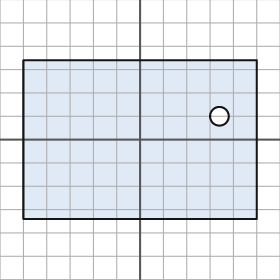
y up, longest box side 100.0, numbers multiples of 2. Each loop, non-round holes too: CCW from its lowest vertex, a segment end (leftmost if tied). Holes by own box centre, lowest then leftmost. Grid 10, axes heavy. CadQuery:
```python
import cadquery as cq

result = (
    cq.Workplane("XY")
    .moveTo(-50.0, -34.0)
    .lineTo(50.0, -34.0)
    .lineTo(50.0, 34.0)
    .lineTo(-50.0, 34.0)
    .close()
    .moveTo(34.0, 10.0)
    .circle(4.0)
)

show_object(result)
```